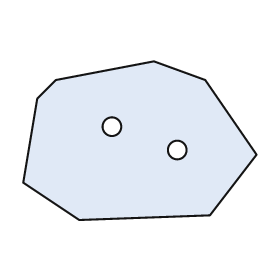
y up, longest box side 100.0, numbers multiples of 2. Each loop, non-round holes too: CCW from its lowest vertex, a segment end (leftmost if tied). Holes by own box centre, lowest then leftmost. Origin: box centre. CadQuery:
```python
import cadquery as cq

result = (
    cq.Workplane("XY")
    .moveTo(-26.0, -34.0)
    .lineTo(30.0, -32.0)
    .lineTo(50.0, -6.0)
    .lineTo(28.0, 26.0)
    .lineTo(6.0, 34.0)
    .lineTo(-36.0, 26.0)
    .lineTo(-44.0, 18.0)
    .lineTo(-50.0, -18.0)
    .close()
    .moveTo(16.0, -4.0)
    .circle(4.0)
    .moveTo(-12.0, 6.0)
    .circle(4.0)
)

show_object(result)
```